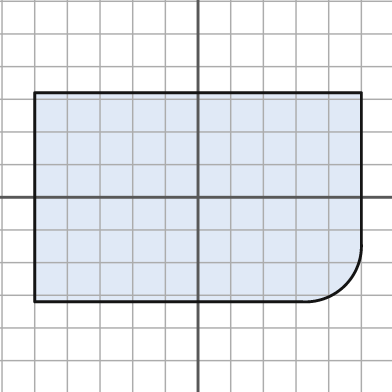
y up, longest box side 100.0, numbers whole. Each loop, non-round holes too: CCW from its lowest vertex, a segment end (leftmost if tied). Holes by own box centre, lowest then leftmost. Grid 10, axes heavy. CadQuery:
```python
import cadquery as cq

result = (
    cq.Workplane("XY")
    .moveTo(-50.0, -32.0)
    .lineTo(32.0, -32.0)
    .threePointArc((45.0, -27.0), (50.0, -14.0))
    .lineTo(50.0, 32.0)
    .lineTo(-50.0, 32.0)
    .close()
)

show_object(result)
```